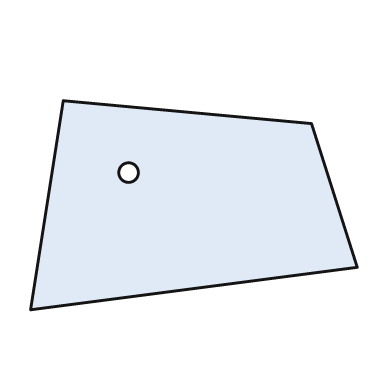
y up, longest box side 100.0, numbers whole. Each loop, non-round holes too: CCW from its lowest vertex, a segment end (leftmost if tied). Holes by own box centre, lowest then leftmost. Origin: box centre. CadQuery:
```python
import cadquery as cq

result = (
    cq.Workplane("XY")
    .moveTo(-50.0, -32.0)
    .lineTo(50.0, -19.0)
    .lineTo(36.0, 25.0)
    .lineTo(-40.0, 32.0)
    .close()
    .moveTo(-20.0, 10.0)
    .circle(3.0)
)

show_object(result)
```